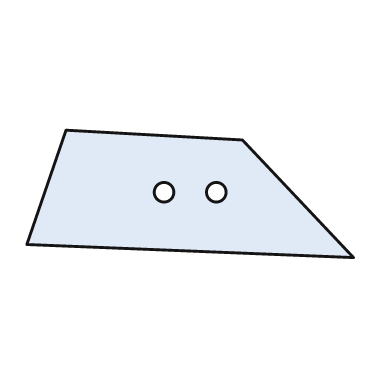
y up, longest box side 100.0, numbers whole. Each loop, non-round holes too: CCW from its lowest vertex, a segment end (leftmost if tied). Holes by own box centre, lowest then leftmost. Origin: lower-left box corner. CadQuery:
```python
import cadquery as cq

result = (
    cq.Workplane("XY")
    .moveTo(100.0, 0.0)
    .lineTo(66.0, 36.0)
    .lineTo(12.0, 39.0)
    .lineTo(0.0, 4.0)
    .close()
    .moveTo(42.0, 20.0)
    .circle(3.0)
    .moveTo(58.0, 20.0)
    .circle(3.0)
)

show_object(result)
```